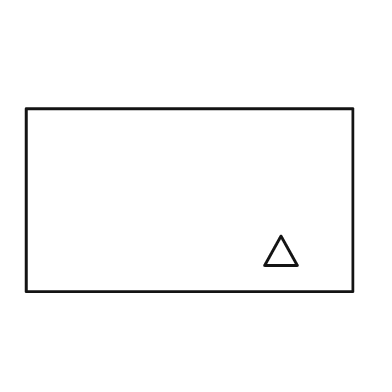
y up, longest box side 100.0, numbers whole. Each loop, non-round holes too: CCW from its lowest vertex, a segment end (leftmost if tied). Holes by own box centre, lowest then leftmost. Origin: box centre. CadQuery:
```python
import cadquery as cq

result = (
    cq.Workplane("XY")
    .moveTo(-50.0, -28.0)
    .lineTo(50.0, -28.0)
    .lineTo(50.0, 28.0)
    .lineTo(-50.0, 28.0)
    .close()
    .moveTo(23.0, -20.0)
    .lineTo(33.0, -20.0)
    .lineTo(28.0, -11.0)
    .close()
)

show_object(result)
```